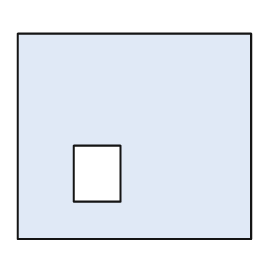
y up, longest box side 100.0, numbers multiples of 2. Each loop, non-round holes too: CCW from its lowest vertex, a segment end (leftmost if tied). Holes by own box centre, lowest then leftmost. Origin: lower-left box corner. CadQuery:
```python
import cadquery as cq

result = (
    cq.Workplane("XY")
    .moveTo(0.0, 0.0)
    .lineTo(100.0, 0.0)
    .lineTo(100.0, 88.0)
    .lineTo(0.0, 88.0)
    .close()
    .moveTo(24.0, 16.0)
    .lineTo(44.0, 16.0)
    .lineTo(44.0, 40.0)
    .lineTo(24.0, 40.0)
    .close()
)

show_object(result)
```